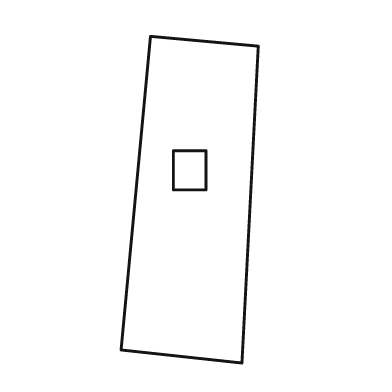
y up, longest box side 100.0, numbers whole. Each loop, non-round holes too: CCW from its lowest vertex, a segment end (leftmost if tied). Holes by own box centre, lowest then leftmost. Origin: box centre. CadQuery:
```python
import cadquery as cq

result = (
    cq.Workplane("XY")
    .moveTo(16.0, -50.0)
    .lineTo(21.0, 47.0)
    .lineTo(-12.0, 50.0)
    .lineTo(-21.0, -46.0)
    .close()
    .moveTo(-5.0, 3.0)
    .lineTo(5.0, 3.0)
    .lineTo(5.0, 15.0)
    .lineTo(-5.0, 15.0)
    .close()
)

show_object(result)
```